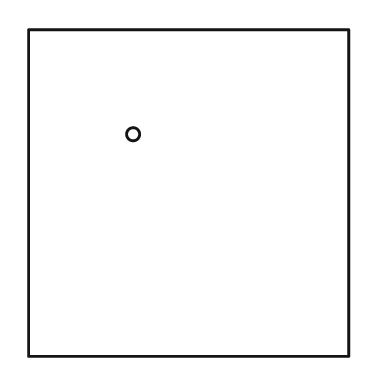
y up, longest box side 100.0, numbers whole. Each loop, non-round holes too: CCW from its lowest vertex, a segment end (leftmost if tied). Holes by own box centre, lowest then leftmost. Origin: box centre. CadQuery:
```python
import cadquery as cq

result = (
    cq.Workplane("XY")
    .moveTo(-49.0, -50.0)
    .lineTo(49.0, -50.0)
    .lineTo(49.0, 50.0)
    .lineTo(-49.0, 50.0)
    .close()
    .moveTo(-17.0, 18.0)
    .circle(2.0)
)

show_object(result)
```